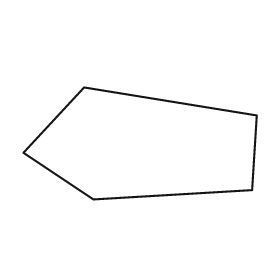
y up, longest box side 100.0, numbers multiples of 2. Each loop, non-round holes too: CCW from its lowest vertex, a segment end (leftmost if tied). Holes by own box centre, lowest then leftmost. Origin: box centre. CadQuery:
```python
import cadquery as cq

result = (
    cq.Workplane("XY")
    .moveTo(-20.0, -24.0)
    .lineTo(48.0, -20.0)
    .lineTo(50.0, 12.0)
    .lineTo(-24.0, 24.0)
    .lineTo(-50.0, -4.0)
    .close()
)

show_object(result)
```